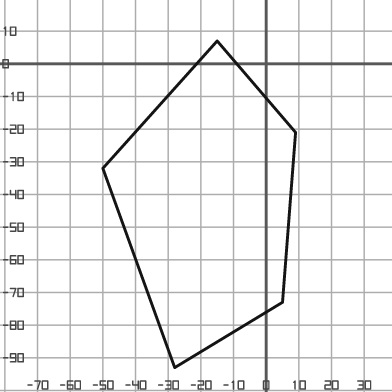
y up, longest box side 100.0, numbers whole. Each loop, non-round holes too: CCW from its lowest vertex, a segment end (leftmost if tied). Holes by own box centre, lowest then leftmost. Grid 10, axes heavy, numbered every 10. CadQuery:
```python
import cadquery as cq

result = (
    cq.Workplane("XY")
    .moveTo(-28.0, -93.0)
    .lineTo(5.0, -73.0)
    .lineTo(9.0, -21.0)
    .lineTo(-15.0, 7.0)
    .lineTo(-50.0, -32.0)
    .close()
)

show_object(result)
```